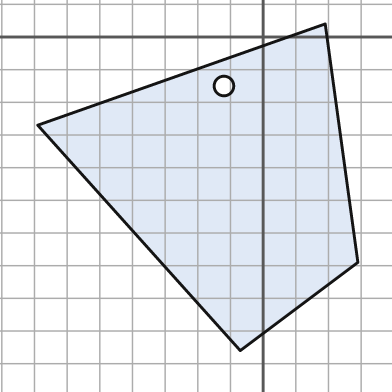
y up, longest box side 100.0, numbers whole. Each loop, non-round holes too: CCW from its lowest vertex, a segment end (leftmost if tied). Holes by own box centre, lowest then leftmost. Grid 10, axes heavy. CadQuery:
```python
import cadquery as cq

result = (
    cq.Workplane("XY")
    .moveTo(-7.0, -96.0)
    .lineTo(29.0, -69.0)
    .lineTo(19.0, 4.0)
    .lineTo(-69.0, -27.0)
    .close()
    .moveTo(-12.0, -15.0)
    .circle(3.0)
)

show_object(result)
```